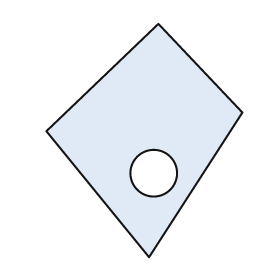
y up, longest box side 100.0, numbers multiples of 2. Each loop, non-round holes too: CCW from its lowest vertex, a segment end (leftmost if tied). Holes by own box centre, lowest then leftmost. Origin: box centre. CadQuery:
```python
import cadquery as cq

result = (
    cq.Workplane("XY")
    .moveTo(2.0, -50.0)
    .lineTo(42.0, 12.0)
    .lineTo(6.0, 50.0)
    .lineTo(-42.0, 4.0)
    .close()
    .moveTo(4.0, -14.0)
    .circle(10.0)
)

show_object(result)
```